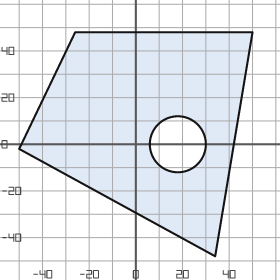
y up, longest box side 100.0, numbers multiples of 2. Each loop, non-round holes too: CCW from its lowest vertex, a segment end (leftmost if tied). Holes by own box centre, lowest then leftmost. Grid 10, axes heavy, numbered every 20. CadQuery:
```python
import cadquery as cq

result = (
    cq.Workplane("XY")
    .moveTo(34.0, -48.0)
    .lineTo(50.0, 48.0)
    .lineTo(-26.0, 48.0)
    .lineTo(-50.0, -2.0)
    .close()
    .moveTo(18.0, 0.0)
    .circle(12.0)
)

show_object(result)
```